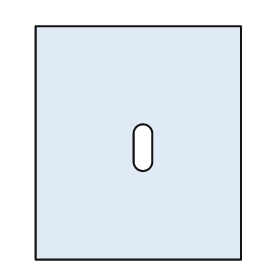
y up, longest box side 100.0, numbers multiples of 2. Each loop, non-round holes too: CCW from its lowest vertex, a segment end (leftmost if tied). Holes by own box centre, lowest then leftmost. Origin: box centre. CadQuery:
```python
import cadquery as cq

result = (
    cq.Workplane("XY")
    .moveTo(-44.0, -50.0)
    .lineTo(44.0, -50.0)
    .lineTo(44.0, 50.0)
    .lineTo(-44.0, 50.0)
    .close()
    .moveTo(-2.0, -8.0)
    .threePointArc((2.0, -12.0), (6.0, -8.0))
    .lineTo(6.0, 4.0)
    .threePointArc((2.0, 8.0), (-2.0, 4.0))
    .close()
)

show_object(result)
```